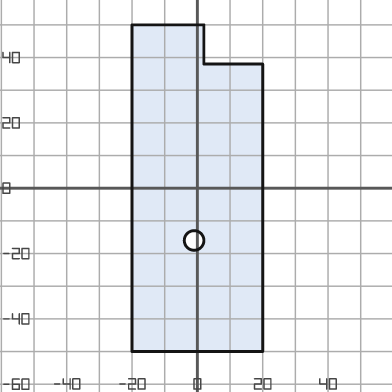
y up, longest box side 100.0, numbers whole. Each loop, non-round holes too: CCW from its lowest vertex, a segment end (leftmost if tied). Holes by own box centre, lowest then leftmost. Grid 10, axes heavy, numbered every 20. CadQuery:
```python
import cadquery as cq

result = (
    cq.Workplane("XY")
    .moveTo(-20.0, -50.0)
    .lineTo(20.0, -50.0)
    .lineTo(20.0, 38.0)
    .lineTo(2.0, 38.0)
    .lineTo(2.0, 50.0)
    .lineTo(-20.0, 50.0)
    .close()
    .moveTo(-1.0, -16.0)
    .circle(3.0)
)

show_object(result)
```